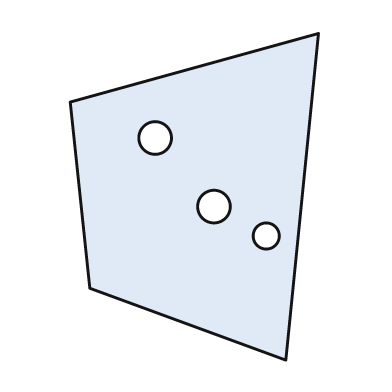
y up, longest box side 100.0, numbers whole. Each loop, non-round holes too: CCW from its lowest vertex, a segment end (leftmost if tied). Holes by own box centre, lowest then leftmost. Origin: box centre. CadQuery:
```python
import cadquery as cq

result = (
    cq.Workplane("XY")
    .moveTo(28.0, -50.0)
    .lineTo(38.0, 50.0)
    .lineTo(-38.0, 29.0)
    .lineTo(-32.0, -28.0)
    .close()
    .moveTo(22.0, -12.0)
    .circle(4.0)
    .moveTo(6.0, -3.0)
    .circle(5.0)
    .moveTo(-12.0, 18.0)
    .circle(5.0)
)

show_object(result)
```